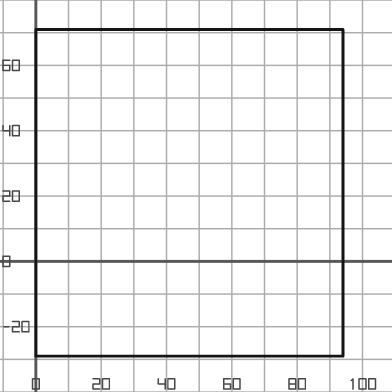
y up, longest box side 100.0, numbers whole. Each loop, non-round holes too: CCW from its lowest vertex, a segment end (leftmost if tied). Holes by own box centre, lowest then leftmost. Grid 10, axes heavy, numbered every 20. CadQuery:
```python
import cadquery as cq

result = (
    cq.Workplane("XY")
    .moveTo(0.0, -29.0)
    .lineTo(94.0, -29.0)
    .lineTo(94.0, 71.0)
    .lineTo(0.0, 71.0)
    .close()
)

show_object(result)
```